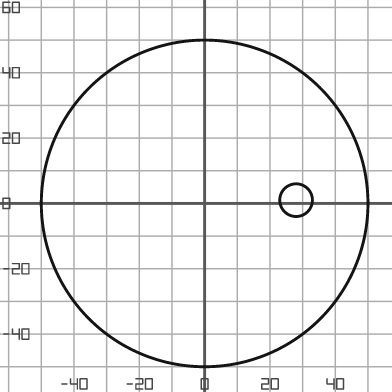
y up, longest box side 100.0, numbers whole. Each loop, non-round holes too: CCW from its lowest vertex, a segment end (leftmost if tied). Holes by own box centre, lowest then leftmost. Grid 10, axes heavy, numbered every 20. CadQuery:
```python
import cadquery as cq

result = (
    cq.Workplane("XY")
    .moveTo(0.0, 0.0)
    .circle(50.0)
    .moveTo(28.0, 1.0)
    .circle(5.0)
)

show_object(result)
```